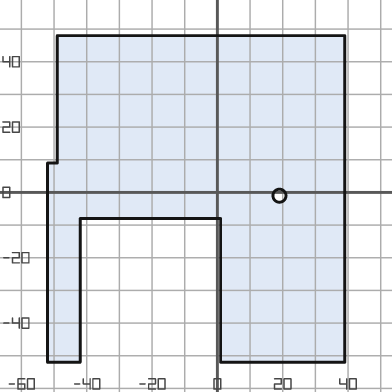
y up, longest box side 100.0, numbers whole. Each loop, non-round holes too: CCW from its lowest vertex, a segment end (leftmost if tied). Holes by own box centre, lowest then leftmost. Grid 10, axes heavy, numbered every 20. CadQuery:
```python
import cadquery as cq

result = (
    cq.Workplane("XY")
    .moveTo(-52.0, -52.0)
    .lineTo(-42.0, -52.0)
    .lineTo(-42.0, -8.0)
    .lineTo(1.0, -8.0)
    .lineTo(1.0, -52.0)
    .lineTo(39.0, -52.0)
    .lineTo(39.0, 48.0)
    .lineTo(-49.0, 48.0)
    .lineTo(-49.0, 9.0)
    .lineTo(-52.0, 9.0)
    .close()
    .moveTo(19.0, -1.0)
    .circle(2.0)
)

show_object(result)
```